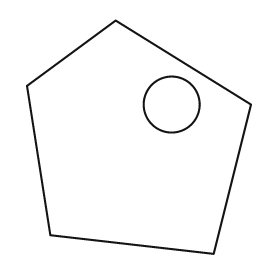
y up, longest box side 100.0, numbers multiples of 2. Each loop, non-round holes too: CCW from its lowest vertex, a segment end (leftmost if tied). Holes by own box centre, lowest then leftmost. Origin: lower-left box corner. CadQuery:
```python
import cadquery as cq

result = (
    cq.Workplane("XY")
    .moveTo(80.0, 0.0)
    .lineTo(96.0, 64.0)
    .lineTo(38.0, 100.0)
    .lineTo(0.0, 72.0)
    .lineTo(10.0, 8.0)
    .close()
    .moveTo(62.0, 64.0)
    .circle(12.0)
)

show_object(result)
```